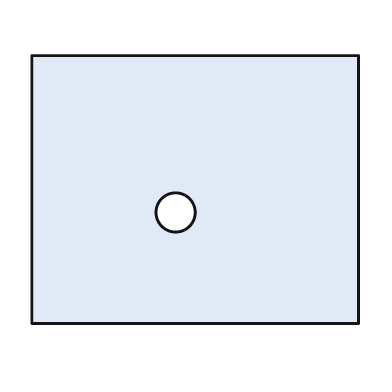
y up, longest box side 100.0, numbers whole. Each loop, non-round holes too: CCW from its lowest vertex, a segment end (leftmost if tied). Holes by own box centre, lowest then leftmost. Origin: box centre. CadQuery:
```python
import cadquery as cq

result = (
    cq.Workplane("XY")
    .moveTo(-50.0, -41.0)
    .lineTo(50.0, -41.0)
    .lineTo(50.0, 41.0)
    .lineTo(-50.0, 41.0)
    .close()
    .moveTo(-6.0, -7.0)
    .circle(6.0)
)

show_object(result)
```